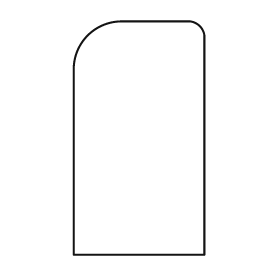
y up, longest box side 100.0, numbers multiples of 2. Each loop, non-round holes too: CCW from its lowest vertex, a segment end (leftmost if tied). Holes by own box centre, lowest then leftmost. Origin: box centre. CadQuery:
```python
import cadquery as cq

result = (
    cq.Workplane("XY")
    .moveTo(-28.0, -50.0)
    .lineTo(28.0, -50.0)
    .lineTo(28.0, 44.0)
    .threePointArc((26.0, 48.0), (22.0, 50.0))
    .lineTo(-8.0, 50.0)
    .threePointArc((-22.0, 44.0), (-28.0, 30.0))
    .close()
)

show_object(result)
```